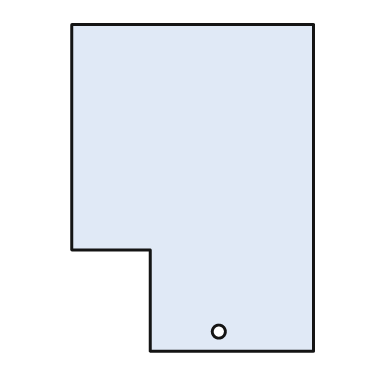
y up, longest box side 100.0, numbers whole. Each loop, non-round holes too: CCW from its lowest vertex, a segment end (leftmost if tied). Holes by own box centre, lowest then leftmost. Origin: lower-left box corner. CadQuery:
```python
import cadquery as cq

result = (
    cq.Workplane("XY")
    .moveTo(24.0, 0.0)
    .lineTo(74.0, 0.0)
    .lineTo(74.0, 100.0)
    .lineTo(0.0, 100.0)
    .lineTo(0.0, 31.0)
    .lineTo(24.0, 31.0)
    .close()
    .moveTo(45.0, 6.0)
    .circle(2.0)
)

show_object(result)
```